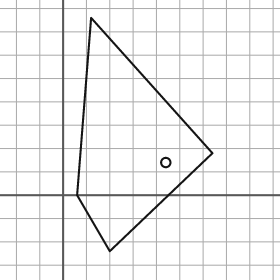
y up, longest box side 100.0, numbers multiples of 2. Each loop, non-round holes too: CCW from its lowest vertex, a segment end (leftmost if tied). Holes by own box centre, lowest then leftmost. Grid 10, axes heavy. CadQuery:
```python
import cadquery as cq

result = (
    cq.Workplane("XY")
    .moveTo(20.0, -24.0)
    .lineTo(64.0, 18.0)
    .lineTo(12.0, 76.0)
    .lineTo(6.0, 0.0)
    .close()
    .moveTo(44.0, 14.0)
    .circle(2.0)
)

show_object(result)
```